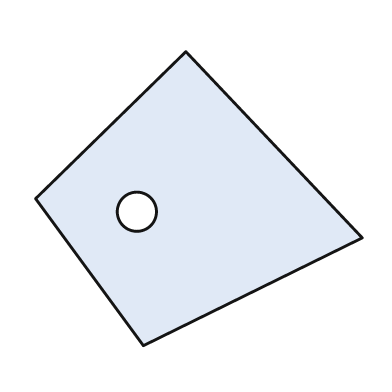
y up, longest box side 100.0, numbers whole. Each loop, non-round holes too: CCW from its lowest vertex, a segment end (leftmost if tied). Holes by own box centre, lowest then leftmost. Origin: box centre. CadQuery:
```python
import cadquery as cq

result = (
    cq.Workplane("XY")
    .moveTo(-17.0, -45.0)
    .lineTo(50.0, -12.0)
    .lineTo(-4.0, 45.0)
    .lineTo(-50.0, 0.0)
    .close()
    .moveTo(-19.0, -4.0)
    .circle(6.0)
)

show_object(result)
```